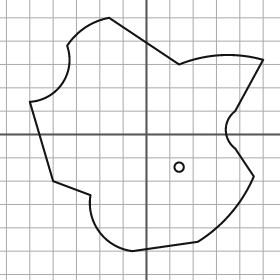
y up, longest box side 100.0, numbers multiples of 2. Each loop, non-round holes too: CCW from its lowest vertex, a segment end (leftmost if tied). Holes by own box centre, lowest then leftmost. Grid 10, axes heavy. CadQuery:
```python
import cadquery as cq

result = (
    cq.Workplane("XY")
    .moveTo(-6.0, -50.0)
    .lineTo(22.0, -46.0)
    .threePointArc((36.0, -34.0), (46.0, -18.0))
    .lineTo(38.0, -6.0)
    .threePointArc((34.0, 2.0), (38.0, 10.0))
    .lineTo(50.0, 32.0)
    .threePointArc((32.0, 34.0), (14.0, 30.0))
    .lineTo(-16.0, 50.0)
    .threePointArc((-26.0, 46.0), (-34.0, 38.0))
    .threePointArc((-36.0, 22.0), (-50.0, 14.0))
    .lineTo(-40.0, -20.0)
    .lineTo(-24.0, -26.0)
    .threePointArc((-20.0, -42.0), (-6.0, -50.0))
    .close()
    .moveTo(14.0, -14.0)
    .circle(2.0)
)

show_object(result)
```